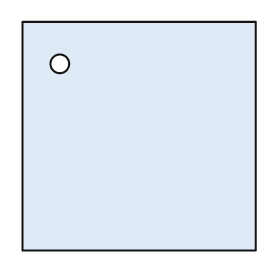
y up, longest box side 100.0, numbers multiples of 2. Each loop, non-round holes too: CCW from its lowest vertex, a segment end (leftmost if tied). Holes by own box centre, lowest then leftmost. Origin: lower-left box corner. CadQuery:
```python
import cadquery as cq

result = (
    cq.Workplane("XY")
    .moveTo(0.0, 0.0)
    .lineTo(100.0, 0.0)
    .lineTo(100.0, 98.0)
    .lineTo(0.0, 98.0)
    .close()
    .moveTo(16.0, 80.0)
    .circle(4.0)
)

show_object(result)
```